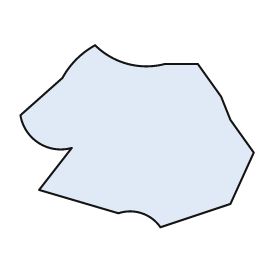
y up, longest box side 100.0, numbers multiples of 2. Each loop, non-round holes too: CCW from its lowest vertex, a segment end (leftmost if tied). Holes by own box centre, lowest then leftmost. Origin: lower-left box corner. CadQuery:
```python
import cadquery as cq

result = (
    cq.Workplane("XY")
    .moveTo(60.0, 0.0)
    .lineTo(90.0, 10.0)
    .lineTo(100.0, 32.0)
    .lineTo(90.0, 46.0)
    .lineTo(86.0, 56.0)
    .lineTo(76.0, 70.0)
    .lineTo(62.0, 70.0)
    .threePointArc((46.0, 70.0), (32.0, 78.0))
    .threePointArc((24.0, 72.0), (18.0, 64.0))
    .lineTo(0.0, 48.0)
    .threePointArc((8.0, 36.0), (22.0, 34.0))
    .lineTo(8.0, 16.0)
    .lineTo(42.0, 6.0)
    .threePointArc((52.0, 6.0), (60.0, 0.0))
    .close()
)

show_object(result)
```